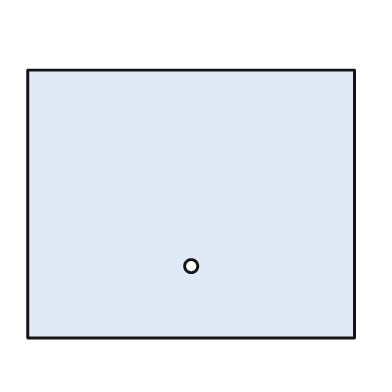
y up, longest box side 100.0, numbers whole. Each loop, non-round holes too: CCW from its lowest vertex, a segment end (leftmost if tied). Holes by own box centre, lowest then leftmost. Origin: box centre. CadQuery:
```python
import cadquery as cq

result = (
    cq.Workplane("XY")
    .moveTo(-50.0, -41.0)
    .lineTo(50.0, -41.0)
    .lineTo(50.0, 41.0)
    .lineTo(-50.0, 41.0)
    .close()
    .moveTo(0.0, -19.0)
    .circle(2.0)
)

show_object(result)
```